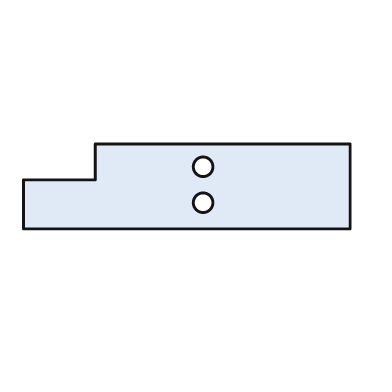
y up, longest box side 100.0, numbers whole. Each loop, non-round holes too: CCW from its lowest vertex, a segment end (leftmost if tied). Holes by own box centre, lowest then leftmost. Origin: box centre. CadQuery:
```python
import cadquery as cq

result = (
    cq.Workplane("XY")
    .moveTo(-50.0, -13.0)
    .lineTo(50.0, -13.0)
    .lineTo(50.0, 13.0)
    .lineTo(-28.0, 13.0)
    .lineTo(-28.0, 2.0)
    .lineTo(-50.0, 2.0)
    .close()
    .moveTo(5.0, -5.0)
    .circle(3.0)
    .moveTo(5.0, 6.0)
    .circle(3.0)
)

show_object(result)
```